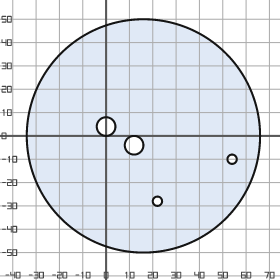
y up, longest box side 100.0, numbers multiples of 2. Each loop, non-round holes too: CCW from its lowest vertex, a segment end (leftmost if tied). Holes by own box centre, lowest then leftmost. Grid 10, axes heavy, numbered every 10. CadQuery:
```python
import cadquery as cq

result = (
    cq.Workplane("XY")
    .moveTo(16.0, 0.0)
    .circle(50.0)
    .moveTo(22.0, -28.0)
    .circle(2.0)
    .moveTo(54.0, -10.0)
    .circle(2.0)
    .moveTo(12.0, -4.0)
    .circle(4.0)
    .moveTo(0.0, 4.0)
    .circle(4.0)
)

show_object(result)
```